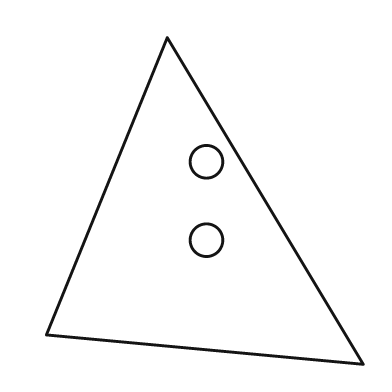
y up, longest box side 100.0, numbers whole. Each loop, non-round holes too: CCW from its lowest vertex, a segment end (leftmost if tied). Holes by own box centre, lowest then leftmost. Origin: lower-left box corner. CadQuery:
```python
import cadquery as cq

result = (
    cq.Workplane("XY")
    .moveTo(97.0, 0.0)
    .lineTo(37.0, 100.0)
    .lineTo(0.0, 9.0)
    .close()
    .moveTo(49.0, 38.0)
    .circle(5.0)
    .moveTo(49.0, 62.0)
    .circle(5.0)
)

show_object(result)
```